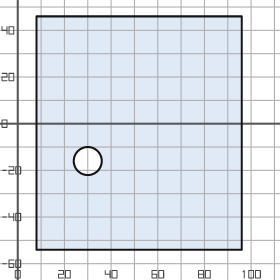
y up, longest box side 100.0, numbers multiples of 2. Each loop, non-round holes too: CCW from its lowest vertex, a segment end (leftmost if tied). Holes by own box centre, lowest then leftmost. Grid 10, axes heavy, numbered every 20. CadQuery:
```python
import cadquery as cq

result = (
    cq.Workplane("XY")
    .moveTo(8.0, -54.0)
    .lineTo(96.0, -54.0)
    .lineTo(96.0, 46.0)
    .lineTo(8.0, 46.0)
    .close()
    .moveTo(30.0, -16.0)
    .circle(6.0)
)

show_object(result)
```